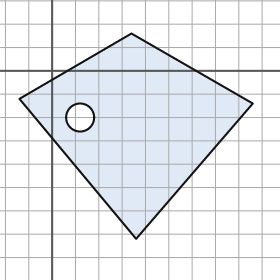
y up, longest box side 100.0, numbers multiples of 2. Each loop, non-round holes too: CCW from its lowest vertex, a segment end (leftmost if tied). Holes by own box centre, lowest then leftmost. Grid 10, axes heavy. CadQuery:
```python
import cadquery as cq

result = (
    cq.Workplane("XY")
    .moveTo(36.0, -72.0)
    .lineTo(86.0, -14.0)
    .lineTo(34.0, 16.0)
    .lineTo(-14.0, -12.0)
    .close()
    .moveTo(12.0, -20.0)
    .circle(6.0)
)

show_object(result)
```